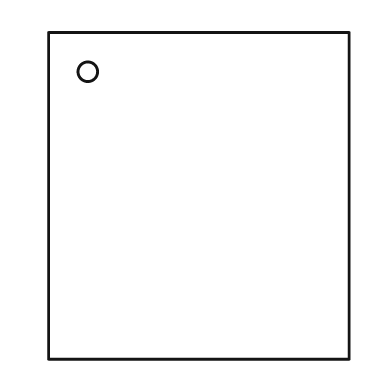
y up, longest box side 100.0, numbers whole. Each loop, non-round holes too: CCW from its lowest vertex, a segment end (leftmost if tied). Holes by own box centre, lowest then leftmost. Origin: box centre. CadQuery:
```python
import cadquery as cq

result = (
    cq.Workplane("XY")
    .moveTo(-46.0, -50.0)
    .lineTo(46.0, -50.0)
    .lineTo(46.0, 50.0)
    .lineTo(-46.0, 50.0)
    .close()
    .moveTo(-34.0, 38.0)
    .circle(3.0)
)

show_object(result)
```